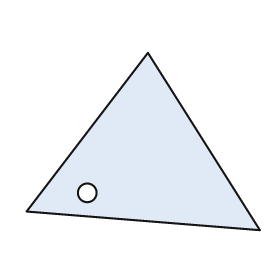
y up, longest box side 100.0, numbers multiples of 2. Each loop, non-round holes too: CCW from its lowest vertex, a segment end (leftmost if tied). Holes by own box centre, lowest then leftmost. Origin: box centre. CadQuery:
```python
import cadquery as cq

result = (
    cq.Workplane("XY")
    .moveTo(50.0, -38.0)
    .lineTo(2.0, 38.0)
    .lineTo(-50.0, -30.0)
    .close()
    .moveTo(-24.0, -22.0)
    .circle(4.0)
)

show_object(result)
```